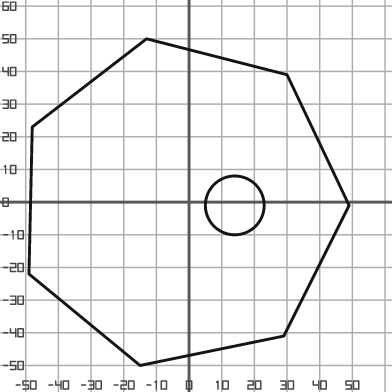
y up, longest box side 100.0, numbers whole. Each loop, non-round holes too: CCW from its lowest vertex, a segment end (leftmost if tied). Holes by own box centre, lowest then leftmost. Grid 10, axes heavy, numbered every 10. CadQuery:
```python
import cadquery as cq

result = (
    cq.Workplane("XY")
    .moveTo(-15.0, -50.0)
    .lineTo(29.0, -41.0)
    .lineTo(49.0, -1.0)
    .lineTo(30.0, 39.0)
    .lineTo(-13.0, 50.0)
    .lineTo(-48.0, 23.0)
    .lineTo(-49.0, -22.0)
    .close()
    .moveTo(14.0, -1.0)
    .circle(9.0)
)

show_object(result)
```